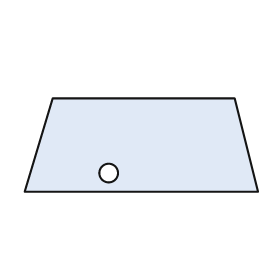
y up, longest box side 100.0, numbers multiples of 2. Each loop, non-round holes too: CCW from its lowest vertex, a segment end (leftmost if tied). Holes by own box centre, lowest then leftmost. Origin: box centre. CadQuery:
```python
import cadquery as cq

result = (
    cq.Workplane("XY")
    .moveTo(-50.0, -20.0)
    .lineTo(50.0, -20.0)
    .lineTo(40.0, 20.0)
    .lineTo(-38.0, 20.0)
    .close()
    .moveTo(-14.0, -12.0)
    .circle(4.0)
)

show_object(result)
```